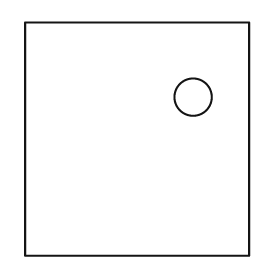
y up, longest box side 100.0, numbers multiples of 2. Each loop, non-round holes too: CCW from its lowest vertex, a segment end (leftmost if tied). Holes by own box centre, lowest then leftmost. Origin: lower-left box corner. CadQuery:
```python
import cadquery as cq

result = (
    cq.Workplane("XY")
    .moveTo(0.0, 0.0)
    .lineTo(96.0, 0.0)
    .lineTo(96.0, 100.0)
    .lineTo(0.0, 100.0)
    .close()
    .moveTo(72.0, 68.0)
    .circle(8.0)
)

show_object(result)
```